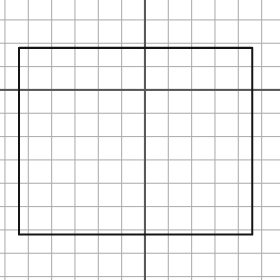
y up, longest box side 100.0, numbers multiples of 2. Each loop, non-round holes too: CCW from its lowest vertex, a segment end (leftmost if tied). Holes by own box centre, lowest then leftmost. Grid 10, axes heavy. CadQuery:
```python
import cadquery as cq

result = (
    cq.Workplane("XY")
    .moveTo(-54.0, -62.0)
    .lineTo(46.0, -62.0)
    .lineTo(46.0, 18.0)
    .lineTo(-54.0, 18.0)
    .close()
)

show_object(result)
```